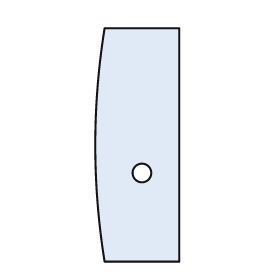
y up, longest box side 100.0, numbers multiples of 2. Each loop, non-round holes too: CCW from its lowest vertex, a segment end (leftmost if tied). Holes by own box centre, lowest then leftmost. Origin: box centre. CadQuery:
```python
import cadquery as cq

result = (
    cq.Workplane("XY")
    .moveTo(-14.0, -50.0)
    .lineTo(18.0, -50.0)
    .lineTo(18.0, 50.0)
    .lineTo(-14.0, 50.0)
    .threePointArc((-18.0, 0.0), (-14.0, -50.0))
    .close()
    .moveTo(2.0, -12.0)
    .circle(4.0)
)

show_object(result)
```